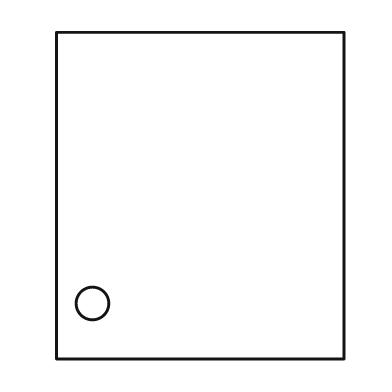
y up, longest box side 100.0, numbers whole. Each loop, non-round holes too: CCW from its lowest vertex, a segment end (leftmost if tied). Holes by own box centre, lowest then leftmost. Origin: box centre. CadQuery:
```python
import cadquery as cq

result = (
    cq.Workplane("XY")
    .moveTo(-44.0, -50.0)
    .lineTo(44.0, -50.0)
    .lineTo(44.0, 50.0)
    .lineTo(-44.0, 50.0)
    .close()
    .moveTo(-33.0, -33.0)
    .circle(5.0)
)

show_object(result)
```